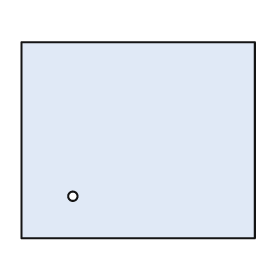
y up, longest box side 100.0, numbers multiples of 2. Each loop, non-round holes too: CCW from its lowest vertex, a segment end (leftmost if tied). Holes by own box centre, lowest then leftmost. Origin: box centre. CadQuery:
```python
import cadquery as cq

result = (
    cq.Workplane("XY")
    .moveTo(-50.0, -42.0)
    .lineTo(50.0, -42.0)
    .lineTo(50.0, 42.0)
    .lineTo(-50.0, 42.0)
    .close()
    .moveTo(-28.0, -24.0)
    .circle(2.0)
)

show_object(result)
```